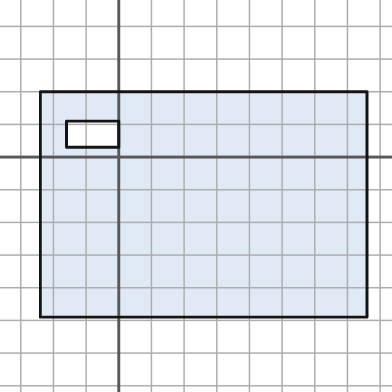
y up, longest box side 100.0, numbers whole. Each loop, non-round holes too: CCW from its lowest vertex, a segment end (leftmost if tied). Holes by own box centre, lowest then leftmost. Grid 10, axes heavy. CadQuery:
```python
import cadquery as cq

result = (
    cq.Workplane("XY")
    .moveTo(-24.0, -49.0)
    .lineTo(76.0, -49.0)
    .lineTo(76.0, 20.0)
    .lineTo(-24.0, 20.0)
    .close()
    .moveTo(-16.0, 3.0)
    .lineTo(0.0, 3.0)
    .lineTo(0.0, 11.0)
    .lineTo(-16.0, 11.0)
    .close()
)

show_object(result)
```